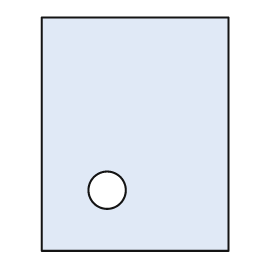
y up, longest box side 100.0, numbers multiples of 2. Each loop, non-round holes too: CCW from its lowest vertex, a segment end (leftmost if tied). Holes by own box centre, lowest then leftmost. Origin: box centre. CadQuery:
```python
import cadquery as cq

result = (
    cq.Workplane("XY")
    .moveTo(-40.0, -50.0)
    .lineTo(40.0, -50.0)
    .lineTo(40.0, 50.0)
    .lineTo(-40.0, 50.0)
    .close()
    .moveTo(-12.0, -24.0)
    .circle(8.0)
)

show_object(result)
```